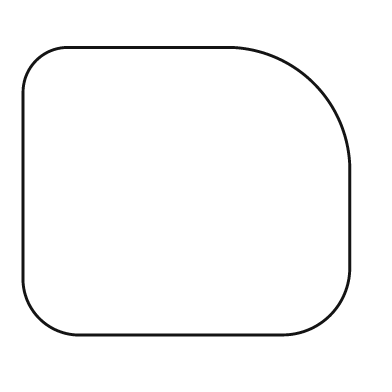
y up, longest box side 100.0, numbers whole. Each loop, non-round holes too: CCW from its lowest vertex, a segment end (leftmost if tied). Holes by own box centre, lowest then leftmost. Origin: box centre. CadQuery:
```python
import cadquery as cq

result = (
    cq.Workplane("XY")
    .moveTo(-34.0, -44.0)
    .lineTo(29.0, -44.0)
    .threePointArc((44.0, -38.0), (50.0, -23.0))
    .lineTo(50.0, 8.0)
    .threePointArc((39.0, 33.0), (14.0, 44.0))
    .lineTo(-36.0, 44.0)
    .threePointArc((-46.0, 40.0), (-50.0, 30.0))
    .lineTo(-50.0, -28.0)
    .threePointArc((-45.0, -39.0), (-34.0, -44.0))
    .close()
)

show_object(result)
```